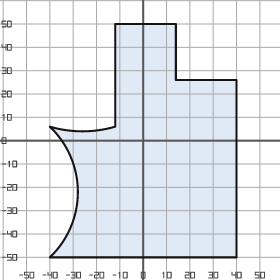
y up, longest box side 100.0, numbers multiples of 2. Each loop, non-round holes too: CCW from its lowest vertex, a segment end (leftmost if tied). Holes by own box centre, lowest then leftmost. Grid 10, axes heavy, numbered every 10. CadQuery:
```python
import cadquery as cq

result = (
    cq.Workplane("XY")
    .moveTo(-40.0, -50.0)
    .lineTo(40.0, -50.0)
    .lineTo(40.0, 26.0)
    .lineTo(14.0, 26.0)
    .lineTo(14.0, 50.0)
    .lineTo(-12.0, 50.0)
    .lineTo(-12.0, 6.0)
    .threePointArc((-26.0, 4.0), (-40.0, 6.0))
    .threePointArc((-28.0, -22.0), (-40.0, -50.0))
    .close()
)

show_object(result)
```